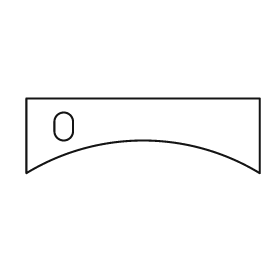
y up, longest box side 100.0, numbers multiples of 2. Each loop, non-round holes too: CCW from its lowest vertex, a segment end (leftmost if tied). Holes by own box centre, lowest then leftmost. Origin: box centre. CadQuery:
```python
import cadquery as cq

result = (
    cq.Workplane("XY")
    .moveTo(-50.0, -16.0)
    .threePointArc((0.0, -2.0), (50.0, -16.0))
    .lineTo(50.0, 16.0)
    .lineTo(-50.0, 16.0)
    .close()
    .moveTo(-38.0, 2.0)
    .threePointArc((-34.0, -2.0), (-30.0, 2.0))
    .lineTo(-30.0, 6.0)
    .threePointArc((-34.0, 10.0), (-38.0, 6.0))
    .close()
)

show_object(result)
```